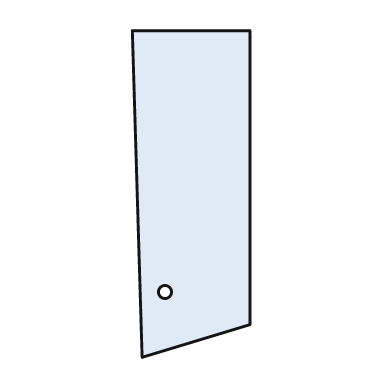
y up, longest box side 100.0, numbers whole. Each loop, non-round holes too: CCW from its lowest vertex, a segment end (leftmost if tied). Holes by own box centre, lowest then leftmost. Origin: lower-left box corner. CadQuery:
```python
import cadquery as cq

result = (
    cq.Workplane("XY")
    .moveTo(3.0, 0.0)
    .lineTo(36.0, 10.0)
    .lineTo(36.0, 100.0)
    .lineTo(0.0, 100.0)
    .close()
    .moveTo(10.0, 20.0)
    .circle(2.0)
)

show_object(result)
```